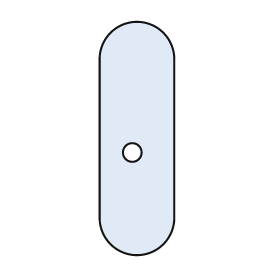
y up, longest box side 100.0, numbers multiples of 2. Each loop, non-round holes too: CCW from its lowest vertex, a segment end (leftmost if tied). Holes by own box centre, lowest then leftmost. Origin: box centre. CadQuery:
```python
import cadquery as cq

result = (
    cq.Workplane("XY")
    .moveTo(-16.0, -34.0)
    .threePointArc((0.0, -50.0), (16.0, -34.0))
    .lineTo(16.0, 34.0)
    .threePointArc((0.0, 50.0), (-16.0, 34.0))
    .close()
    .moveTo(-2.0, -6.0)
    .circle(4.0)
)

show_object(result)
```